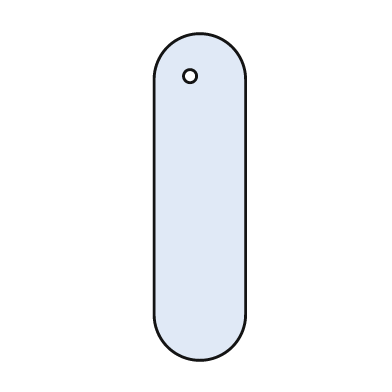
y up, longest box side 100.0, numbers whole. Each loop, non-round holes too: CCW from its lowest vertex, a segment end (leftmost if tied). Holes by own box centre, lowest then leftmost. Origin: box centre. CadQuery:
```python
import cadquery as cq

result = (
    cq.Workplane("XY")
    .moveTo(-14.0, -36.0)
    .threePointArc((0.0, -50.0), (14.0, -36.0))
    .lineTo(14.0, 36.0)
    .threePointArc((0.0, 50.0), (-14.0, 36.0))
    .close()
    .moveTo(-3.0, 37.0)
    .circle(2.0)
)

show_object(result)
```